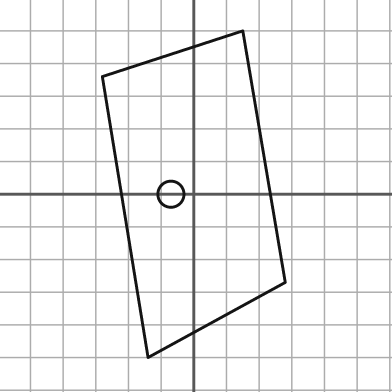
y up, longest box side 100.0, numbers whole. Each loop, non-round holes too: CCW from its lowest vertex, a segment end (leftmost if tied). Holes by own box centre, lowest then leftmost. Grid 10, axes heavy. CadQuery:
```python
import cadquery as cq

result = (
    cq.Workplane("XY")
    .moveTo(-14.0, -50.0)
    .lineTo(28.0, -27.0)
    .lineTo(15.0, 50.0)
    .lineTo(-28.0, 36.0)
    .close()
    .moveTo(-7.0, 0.0)
    .circle(4.0)
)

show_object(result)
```